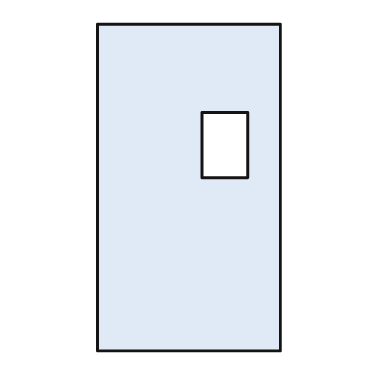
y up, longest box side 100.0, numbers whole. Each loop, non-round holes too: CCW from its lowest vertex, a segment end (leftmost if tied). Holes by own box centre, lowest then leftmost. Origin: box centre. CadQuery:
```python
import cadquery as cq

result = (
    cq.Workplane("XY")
    .moveTo(-28.0, -50.0)
    .lineTo(28.0, -50.0)
    .lineTo(28.0, 50.0)
    .lineTo(-28.0, 50.0)
    .close()
    .moveTo(4.0, 3.0)
    .lineTo(18.0, 3.0)
    .lineTo(18.0, 23.0)
    .lineTo(4.0, 23.0)
    .close()
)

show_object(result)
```